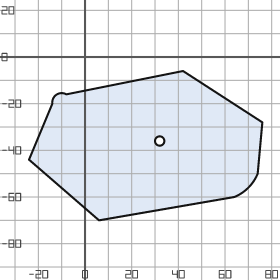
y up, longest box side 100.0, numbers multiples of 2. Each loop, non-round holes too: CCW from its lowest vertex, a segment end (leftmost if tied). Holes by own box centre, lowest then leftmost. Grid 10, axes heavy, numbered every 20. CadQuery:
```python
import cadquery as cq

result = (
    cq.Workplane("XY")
    .moveTo(6.0, -70.0)
    .lineTo(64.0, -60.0)
    .threePointArc((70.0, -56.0), (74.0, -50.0))
    .lineTo(76.0, -28.0)
    .lineTo(42.0, -6.0)
    .lineTo(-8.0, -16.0)
    .threePointArc((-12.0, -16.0), (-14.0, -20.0))
    .lineTo(-24.0, -44.0)
    .close()
    .moveTo(32.0, -36.0)
    .circle(2.0)
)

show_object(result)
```